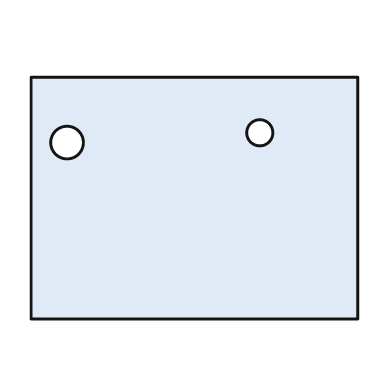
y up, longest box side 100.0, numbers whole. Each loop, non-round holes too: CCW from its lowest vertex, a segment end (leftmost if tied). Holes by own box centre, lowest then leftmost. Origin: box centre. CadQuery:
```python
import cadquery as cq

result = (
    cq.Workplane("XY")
    .moveTo(-50.0, -37.0)
    .lineTo(50.0, -37.0)
    .lineTo(50.0, 37.0)
    .lineTo(-50.0, 37.0)
    .close()
    .moveTo(-39.0, 17.0)
    .circle(5.0)
    .moveTo(20.0, 20.0)
    .circle(4.0)
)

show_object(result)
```